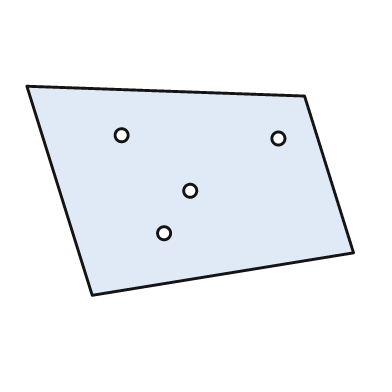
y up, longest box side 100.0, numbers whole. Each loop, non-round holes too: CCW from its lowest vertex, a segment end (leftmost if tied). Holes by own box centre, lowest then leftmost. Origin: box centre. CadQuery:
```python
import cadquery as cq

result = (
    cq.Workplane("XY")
    .moveTo(-30.0, -32.0)
    .lineTo(50.0, -19.0)
    .lineTo(35.0, 29.0)
    .lineTo(-50.0, 32.0)
    .close()
    .moveTo(-8.0, -13.0)
    .circle(2.0)
    .moveTo(0.0, 0.0)
    .circle(2.0)
    .moveTo(27.0, 16.0)
    .circle(2.0)
    .moveTo(-21.0, 17.0)
    .circle(2.0)
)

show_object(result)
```